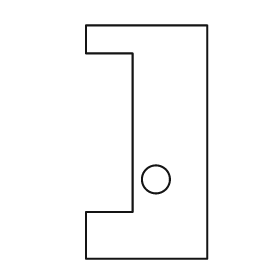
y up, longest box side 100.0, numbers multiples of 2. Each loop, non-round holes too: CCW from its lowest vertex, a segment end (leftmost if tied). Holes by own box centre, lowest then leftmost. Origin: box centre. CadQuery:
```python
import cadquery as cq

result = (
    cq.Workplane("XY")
    .moveTo(-26.0, -50.0)
    .lineTo(26.0, -50.0)
    .lineTo(26.0, 50.0)
    .lineTo(-26.0, 50.0)
    .lineTo(-26.0, 38.0)
    .lineTo(-6.0, 38.0)
    .lineTo(-6.0, -30.0)
    .lineTo(-26.0, -30.0)
    .close()
    .moveTo(4.0, -16.0)
    .circle(6.0)
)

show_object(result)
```